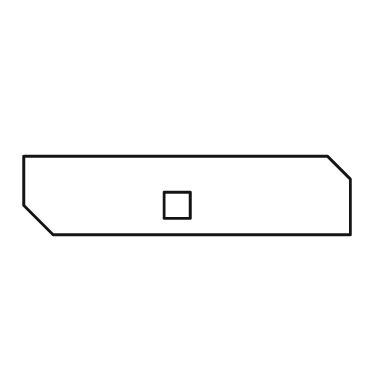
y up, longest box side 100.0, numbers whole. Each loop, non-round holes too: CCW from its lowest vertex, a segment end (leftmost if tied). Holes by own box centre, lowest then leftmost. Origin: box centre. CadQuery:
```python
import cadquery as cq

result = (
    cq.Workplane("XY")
    .moveTo(-41.0, -12.0)
    .lineTo(50.0, -12.0)
    .lineTo(50.0, 5.0)
    .lineTo(43.0, 12.0)
    .lineTo(-50.0, 12.0)
    .lineTo(-50.0, -3.0)
    .close()
    .moveTo(-7.0, -7.0)
    .lineTo(1.0, -7.0)
    .lineTo(1.0, 1.0)
    .lineTo(-7.0, 1.0)
    .close()
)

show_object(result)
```